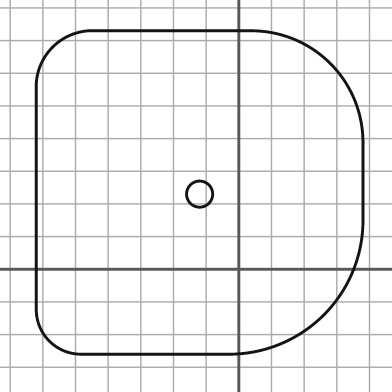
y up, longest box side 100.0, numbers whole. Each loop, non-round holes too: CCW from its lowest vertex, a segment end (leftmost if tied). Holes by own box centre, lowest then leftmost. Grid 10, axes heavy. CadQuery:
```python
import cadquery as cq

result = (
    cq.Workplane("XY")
    .moveTo(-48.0, -26.0)
    .lineTo(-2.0, -26.0)
    .threePointArc((26.0, -14.0), (38.0, 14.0))
    .lineTo(38.0, 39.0)
    .threePointArc((28.0, 63.0), (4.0, 73.0))
    .lineTo(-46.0, 73.0)
    .threePointArc((-57.0, 68.0), (-62.0, 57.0))
    .lineTo(-62.0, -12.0)
    .threePointArc((-58.0, -22.0), (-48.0, -26.0))
    .close()
    .moveTo(-12.0, 23.0)
    .circle(4.0)
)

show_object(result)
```